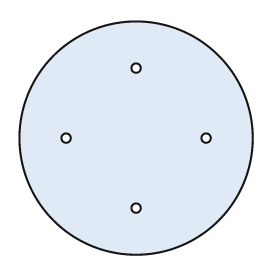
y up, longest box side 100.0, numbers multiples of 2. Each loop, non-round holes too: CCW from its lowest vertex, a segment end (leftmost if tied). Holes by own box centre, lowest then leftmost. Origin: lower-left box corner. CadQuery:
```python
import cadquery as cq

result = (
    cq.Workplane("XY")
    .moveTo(50.0, 50.0)
    .circle(50.0)
    .moveTo(50.0, 20.0)
    .circle(2.0)
    .moveTo(20.0, 50.0)
    .circle(2.0)
    .moveTo(80.0, 50.0)
    .circle(2.0)
    .moveTo(50.0, 80.0)
    .circle(2.0)
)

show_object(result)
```